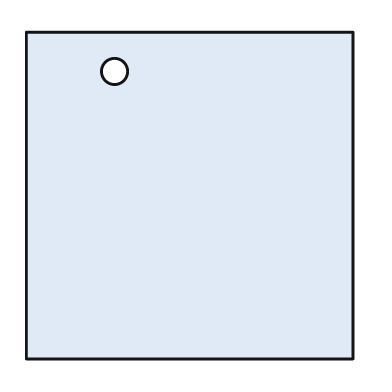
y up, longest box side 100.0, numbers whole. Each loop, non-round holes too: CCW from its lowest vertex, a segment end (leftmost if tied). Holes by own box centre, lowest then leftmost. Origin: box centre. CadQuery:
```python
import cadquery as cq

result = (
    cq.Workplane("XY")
    .moveTo(-50.0, -50.0)
    .lineTo(50.0, -50.0)
    .lineTo(50.0, 50.0)
    .lineTo(-50.0, 50.0)
    .close()
    .moveTo(-23.0, 38.0)
    .circle(4.0)
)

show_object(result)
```